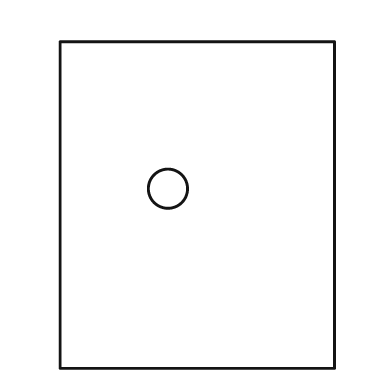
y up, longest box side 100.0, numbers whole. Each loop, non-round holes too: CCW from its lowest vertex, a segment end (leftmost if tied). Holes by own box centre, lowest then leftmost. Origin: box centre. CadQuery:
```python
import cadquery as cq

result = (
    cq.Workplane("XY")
    .moveTo(-42.0, -50.0)
    .lineTo(42.0, -50.0)
    .lineTo(42.0, 50.0)
    .lineTo(-42.0, 50.0)
    .close()
    .moveTo(-9.0, 5.0)
    .circle(6.0)
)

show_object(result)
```